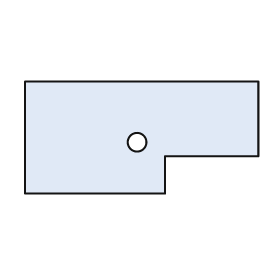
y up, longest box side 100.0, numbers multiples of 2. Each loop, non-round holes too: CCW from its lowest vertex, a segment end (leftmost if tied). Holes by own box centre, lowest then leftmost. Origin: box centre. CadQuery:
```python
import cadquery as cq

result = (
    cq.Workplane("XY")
    .moveTo(-50.0, -24.0)
    .lineTo(10.0, -24.0)
    .lineTo(10.0, -8.0)
    .lineTo(50.0, -8.0)
    .lineTo(50.0, 24.0)
    .lineTo(-50.0, 24.0)
    .close()
    .moveTo(-2.0, -2.0)
    .circle(4.0)
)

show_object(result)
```